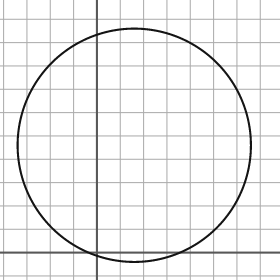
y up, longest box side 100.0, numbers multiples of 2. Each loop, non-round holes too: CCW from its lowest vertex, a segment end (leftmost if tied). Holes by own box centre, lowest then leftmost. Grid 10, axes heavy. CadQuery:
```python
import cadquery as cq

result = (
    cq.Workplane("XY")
    .moveTo(16.0, 46.0)
    .circle(50.0)
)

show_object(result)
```